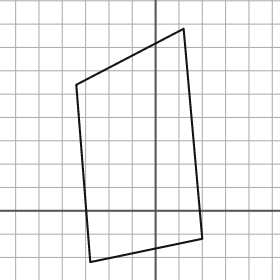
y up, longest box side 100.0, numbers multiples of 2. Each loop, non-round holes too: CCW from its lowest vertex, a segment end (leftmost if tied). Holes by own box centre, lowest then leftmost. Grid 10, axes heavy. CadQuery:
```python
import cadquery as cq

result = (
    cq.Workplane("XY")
    .moveTo(-28.0, -22.0)
    .lineTo(20.0, -12.0)
    .lineTo(12.0, 78.0)
    .lineTo(-34.0, 54.0)
    .close()
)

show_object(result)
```